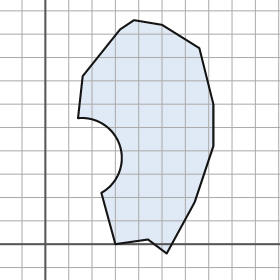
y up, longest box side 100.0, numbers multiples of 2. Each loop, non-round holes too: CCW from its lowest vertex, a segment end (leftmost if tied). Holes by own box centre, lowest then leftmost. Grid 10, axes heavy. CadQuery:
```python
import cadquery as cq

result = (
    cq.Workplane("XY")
    .moveTo(52.0, -4.0)
    .lineTo(64.0, 18.0)
    .lineTo(72.0, 42.0)
    .lineTo(72.0, 60.0)
    .lineTo(66.0, 84.0)
    .lineTo(50.0, 94.0)
    .lineTo(38.0, 96.0)
    .lineTo(32.0, 92.0)
    .lineTo(16.0, 72.0)
    .lineTo(14.0, 54.0)
    .threePointArc((32.0, 42.0), (24.0, 22.0))
    .lineTo(30.0, 0.0)
    .lineTo(44.0, 2.0)
    .close()
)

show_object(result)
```